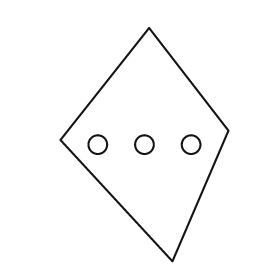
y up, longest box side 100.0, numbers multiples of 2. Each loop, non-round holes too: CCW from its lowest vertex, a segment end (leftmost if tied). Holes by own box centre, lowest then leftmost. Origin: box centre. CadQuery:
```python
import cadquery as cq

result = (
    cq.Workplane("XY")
    .moveTo(12.0, -50.0)
    .lineTo(36.0, 6.0)
    .lineTo(2.0, 50.0)
    .lineTo(-36.0, 2.0)
    .close()
    .moveTo(-20.0, 0.0)
    .circle(4.0)
    .moveTo(0.0, 0.0)
    .circle(4.0)
    .moveTo(20.0, 0.0)
    .circle(4.0)
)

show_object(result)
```